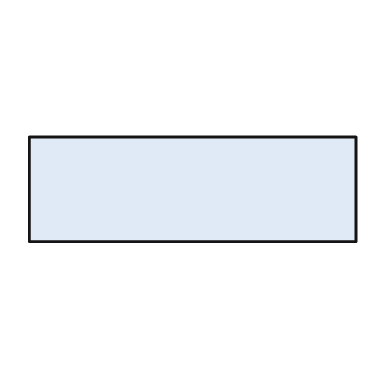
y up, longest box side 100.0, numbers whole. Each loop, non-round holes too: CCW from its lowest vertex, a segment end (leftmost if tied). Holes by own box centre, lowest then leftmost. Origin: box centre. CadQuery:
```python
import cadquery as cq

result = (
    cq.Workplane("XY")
    .moveTo(-50.0, -16.0)
    .lineTo(50.0, -16.0)
    .lineTo(50.0, 16.0)
    .lineTo(-50.0, 16.0)
    .close()
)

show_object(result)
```